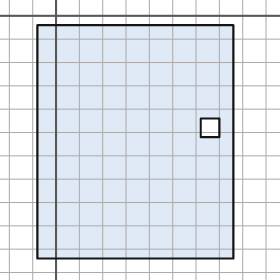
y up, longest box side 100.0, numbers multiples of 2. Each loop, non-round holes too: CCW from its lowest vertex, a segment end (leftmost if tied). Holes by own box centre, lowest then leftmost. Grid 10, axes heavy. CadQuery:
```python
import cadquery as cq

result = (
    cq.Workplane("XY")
    .moveTo(-8.0, -104.0)
    .lineTo(76.0, -104.0)
    .lineTo(76.0, -4.0)
    .lineTo(-8.0, -4.0)
    .close()
    .moveTo(62.0, -52.0)
    .lineTo(70.0, -52.0)
    .lineTo(70.0, -44.0)
    .lineTo(62.0, -44.0)
    .close()
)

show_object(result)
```